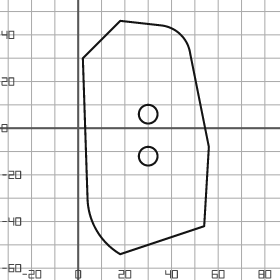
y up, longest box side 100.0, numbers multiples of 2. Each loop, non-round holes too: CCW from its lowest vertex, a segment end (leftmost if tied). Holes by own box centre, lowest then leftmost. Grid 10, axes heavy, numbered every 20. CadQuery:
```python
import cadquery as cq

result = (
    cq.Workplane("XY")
    .moveTo(18.0, -54.0)
    .lineTo(54.0, -42.0)
    .lineTo(56.0, -8.0)
    .lineTo(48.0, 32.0)
    .threePointArc((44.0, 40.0), (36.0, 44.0))
    .lineTo(18.0, 46.0)
    .lineTo(2.0, 30.0)
    .lineTo(4.0, -30.0)
    .threePointArc((8.0, -44.0), (18.0, -54.0))
    .close()
    .moveTo(30.0, -12.0)
    .circle(4.0)
    .moveTo(30.0, 6.0)
    .circle(4.0)
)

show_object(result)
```